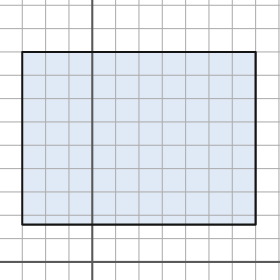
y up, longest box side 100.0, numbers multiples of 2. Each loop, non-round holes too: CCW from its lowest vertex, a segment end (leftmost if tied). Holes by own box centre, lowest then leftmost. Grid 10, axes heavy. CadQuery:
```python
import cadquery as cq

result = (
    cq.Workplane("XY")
    .moveTo(-30.0, 16.0)
    .lineTo(70.0, 16.0)
    .lineTo(70.0, 90.0)
    .lineTo(-30.0, 90.0)
    .close()
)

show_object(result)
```